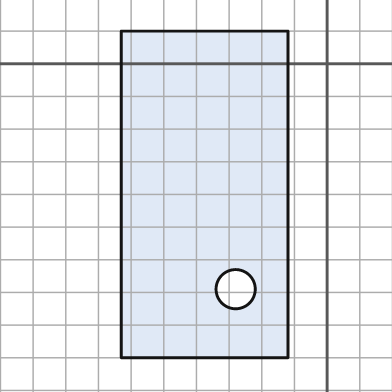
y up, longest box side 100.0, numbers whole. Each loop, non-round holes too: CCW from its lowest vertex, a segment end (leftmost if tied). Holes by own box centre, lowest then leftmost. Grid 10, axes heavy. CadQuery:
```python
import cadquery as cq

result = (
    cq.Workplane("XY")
    .moveTo(-63.0, -90.0)
    .lineTo(-12.0, -90.0)
    .lineTo(-12.0, 10.0)
    .lineTo(-63.0, 10.0)
    .close()
    .moveTo(-28.0, -69.0)
    .circle(6.0)
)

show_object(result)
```